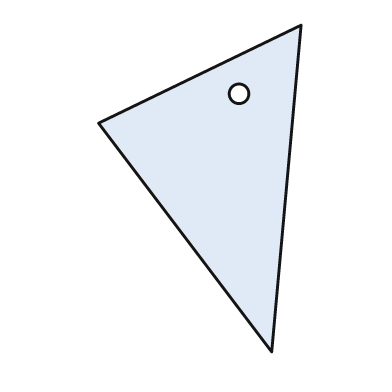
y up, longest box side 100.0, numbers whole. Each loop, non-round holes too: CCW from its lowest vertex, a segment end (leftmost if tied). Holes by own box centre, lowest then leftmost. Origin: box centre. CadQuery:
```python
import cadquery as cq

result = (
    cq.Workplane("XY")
    .moveTo(22.0, -50.0)
    .lineTo(31.0, 50.0)
    .lineTo(-31.0, 20.0)
    .close()
    .moveTo(12.0, 29.0)
    .circle(3.0)
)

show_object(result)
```